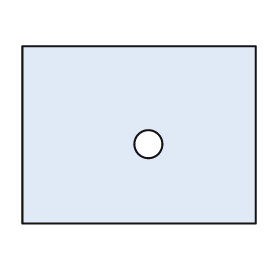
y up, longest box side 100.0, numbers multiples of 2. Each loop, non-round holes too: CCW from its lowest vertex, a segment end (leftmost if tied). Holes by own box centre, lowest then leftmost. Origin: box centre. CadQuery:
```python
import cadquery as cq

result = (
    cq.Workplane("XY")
    .moveTo(-50.0, -38.0)
    .lineTo(50.0, -38.0)
    .lineTo(50.0, 38.0)
    .lineTo(-50.0, 38.0)
    .close()
    .moveTo(4.0, -4.0)
    .circle(6.0)
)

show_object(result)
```